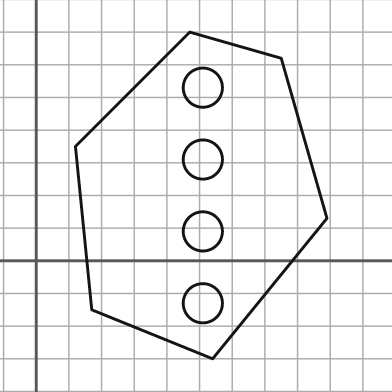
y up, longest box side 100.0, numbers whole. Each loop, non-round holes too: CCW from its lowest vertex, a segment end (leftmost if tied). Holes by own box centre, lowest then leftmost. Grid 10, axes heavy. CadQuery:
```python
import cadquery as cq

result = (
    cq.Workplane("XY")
    .moveTo(54.0, -30.0)
    .lineTo(89.0, 13.0)
    .lineTo(75.0, 62.0)
    .lineTo(47.0, 70.0)
    .lineTo(12.0, 35.0)
    .lineTo(17.0, -15.0)
    .close()
    .moveTo(51.0, -13.0)
    .circle(6.0)
    .moveTo(51.0, 9.0)
    .circle(6.0)
    .moveTo(51.0, 31.0)
    .circle(6.0)
    .moveTo(51.0, 53.0)
    .circle(6.0)
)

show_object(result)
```